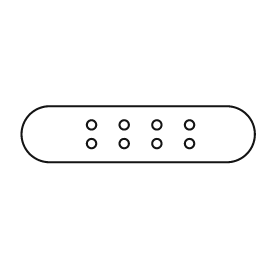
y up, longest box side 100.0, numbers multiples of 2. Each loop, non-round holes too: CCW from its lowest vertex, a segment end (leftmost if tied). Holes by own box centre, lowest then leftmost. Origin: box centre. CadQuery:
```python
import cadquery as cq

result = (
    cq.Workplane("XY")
    .moveTo(-38.0, -12.0)
    .lineTo(38.0, -12.0)
    .threePointArc((50.0, 0.0), (38.0, 12.0))
    .lineTo(-38.0, 12.0)
    .threePointArc((-50.0, 0.0), (-38.0, -12.0))
    .close()
    .moveTo(-20.0, -4.0)
    .circle(2.0)
    .moveTo(-6.0, -4.0)
    .circle(2.0)
    .moveTo(8.0, -4.0)
    .circle(2.0)
    .moveTo(22.0, -4.0)
    .circle(2.0)
    .moveTo(-20.0, 4.0)
    .circle(2.0)
    .moveTo(-6.0, 4.0)
    .circle(2.0)
    .moveTo(8.0, 4.0)
    .circle(2.0)
    .moveTo(22.0, 4.0)
    .circle(2.0)
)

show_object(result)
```